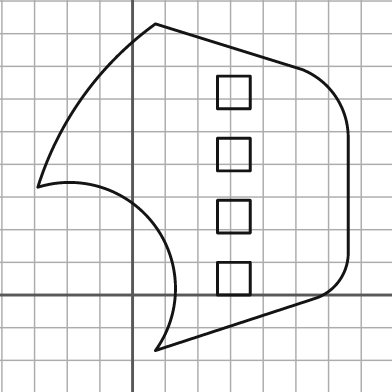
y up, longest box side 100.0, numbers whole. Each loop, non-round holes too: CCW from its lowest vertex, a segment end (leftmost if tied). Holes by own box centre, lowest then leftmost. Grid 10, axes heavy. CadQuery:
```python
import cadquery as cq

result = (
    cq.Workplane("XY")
    .moveTo(7.0, -17.0)
    .lineTo(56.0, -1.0)
    .threePointArc((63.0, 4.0), (66.0, 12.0))
    .lineTo(66.0, 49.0)
    .threePointArc((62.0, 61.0), (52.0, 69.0))
    .lineTo(7.0, 83.0)
    .threePointArc((-15.0, 61.0), (-29.0, 33.0))
    .threePointArc((7.0, 21.0), (7.0, -17.0))
    .close()
    .moveTo(26.0, 0.0)
    .lineTo(36.0, 0.0)
    .lineTo(36.0, 10.0)
    .lineTo(26.0, 10.0)
    .close()
    .moveTo(26.0, 19.0)
    .lineTo(36.0, 19.0)
    .lineTo(36.0, 29.0)
    .lineTo(26.0, 29.0)
    .close()
    .moveTo(26.0, 38.0)
    .lineTo(36.0, 38.0)
    .lineTo(36.0, 48.0)
    .lineTo(26.0, 48.0)
    .close()
    .moveTo(26.0, 57.0)
    .lineTo(36.0, 57.0)
    .lineTo(36.0, 67.0)
    .lineTo(26.0, 67.0)
    .close()
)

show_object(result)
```